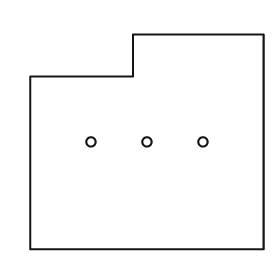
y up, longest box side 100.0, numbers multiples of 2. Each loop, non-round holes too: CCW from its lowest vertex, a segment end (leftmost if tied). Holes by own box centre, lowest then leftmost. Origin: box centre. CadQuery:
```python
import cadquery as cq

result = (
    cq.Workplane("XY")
    .moveTo(-50.0, -46.0)
    .lineTo(50.0, -46.0)
    .lineTo(50.0, 46.0)
    .lineTo(-6.0, 46.0)
    .lineTo(-6.0, 28.0)
    .lineTo(-50.0, 28.0)
    .close()
    .moveTo(-24.0, 0.0)
    .circle(2.0)
    .moveTo(0.0, 0.0)
    .circle(2.0)
    .moveTo(24.0, 0.0)
    .circle(2.0)
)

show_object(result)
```